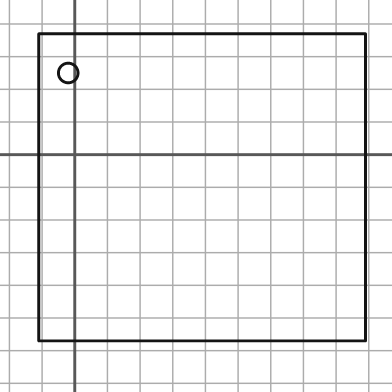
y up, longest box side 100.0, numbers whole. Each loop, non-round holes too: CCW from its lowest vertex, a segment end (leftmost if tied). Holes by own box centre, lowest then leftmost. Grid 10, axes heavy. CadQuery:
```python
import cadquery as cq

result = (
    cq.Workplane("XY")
    .moveTo(-11.0, -57.0)
    .lineTo(89.0, -57.0)
    .lineTo(89.0, 37.0)
    .lineTo(-11.0, 37.0)
    .close()
    .moveTo(-2.0, 25.0)
    .circle(3.0)
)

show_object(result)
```